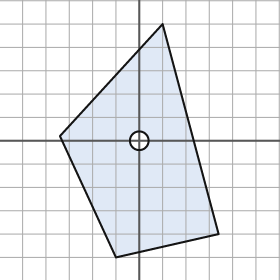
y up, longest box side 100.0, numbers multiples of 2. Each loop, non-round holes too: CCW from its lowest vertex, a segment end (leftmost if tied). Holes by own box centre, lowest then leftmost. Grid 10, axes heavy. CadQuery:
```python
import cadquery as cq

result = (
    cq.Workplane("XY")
    .moveTo(-10.0, -50.0)
    .lineTo(34.0, -40.0)
    .lineTo(10.0, 50.0)
    .lineTo(-34.0, 2.0)
    .close()
    .moveTo(0.0, 0.0)
    .circle(4.0)
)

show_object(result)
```